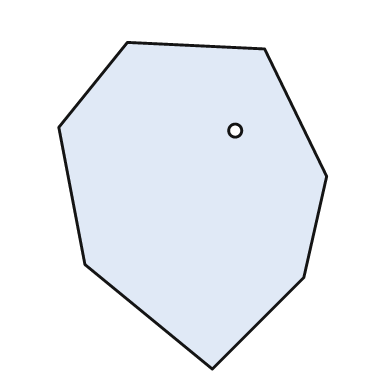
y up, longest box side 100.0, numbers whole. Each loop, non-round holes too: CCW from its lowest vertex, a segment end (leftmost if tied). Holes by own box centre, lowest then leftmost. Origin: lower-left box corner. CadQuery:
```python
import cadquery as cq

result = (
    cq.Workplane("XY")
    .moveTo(47.0, 0.0)
    .lineTo(75.0, 28.0)
    .lineTo(82.0, 59.0)
    .lineTo(63.0, 98.0)
    .lineTo(21.0, 100.0)
    .lineTo(0.0, 74.0)
    .lineTo(8.0, 32.0)
    .close()
    .moveTo(54.0, 73.0)
    .circle(2.0)
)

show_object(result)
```